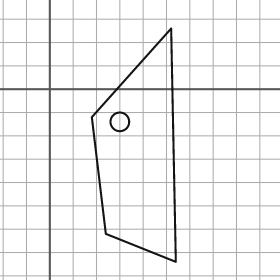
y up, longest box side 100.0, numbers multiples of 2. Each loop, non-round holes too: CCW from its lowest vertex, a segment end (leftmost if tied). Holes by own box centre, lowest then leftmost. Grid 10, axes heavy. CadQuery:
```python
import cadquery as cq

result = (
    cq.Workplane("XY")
    .moveTo(54.0, -74.0)
    .lineTo(52.0, 26.0)
    .lineTo(18.0, -12.0)
    .lineTo(24.0, -62.0)
    .close()
    .moveTo(30.0, -14.0)
    .circle(4.0)
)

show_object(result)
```